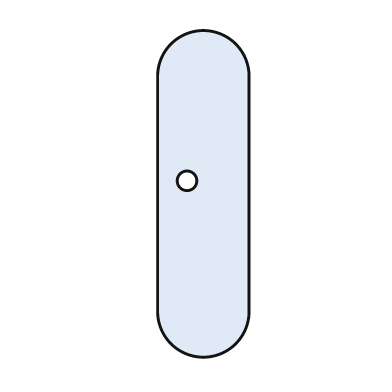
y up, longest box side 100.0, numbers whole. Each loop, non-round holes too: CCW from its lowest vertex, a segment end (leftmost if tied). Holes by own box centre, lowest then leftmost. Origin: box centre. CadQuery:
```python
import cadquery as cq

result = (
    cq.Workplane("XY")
    .moveTo(-14.0, -36.0)
    .threePointArc((0.0, -50.0), (14.0, -36.0))
    .lineTo(14.0, 36.0)
    .threePointArc((0.0, 50.0), (-14.0, 36.0))
    .close()
    .moveTo(-5.0, 4.0)
    .circle(3.0)
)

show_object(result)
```